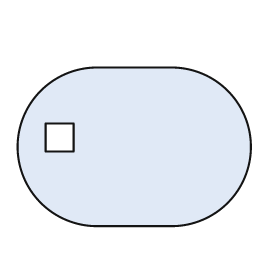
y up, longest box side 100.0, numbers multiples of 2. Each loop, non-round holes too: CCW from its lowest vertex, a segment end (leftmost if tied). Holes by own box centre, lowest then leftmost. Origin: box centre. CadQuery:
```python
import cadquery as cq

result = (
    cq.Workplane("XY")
    .moveTo(-16.0, -34.0)
    .lineTo(16.0, -34.0)
    .threePointArc((50.0, 0.0), (16.0, 34.0))
    .lineTo(-16.0, 34.0)
    .threePointArc((-50.0, 0.0), (-16.0, -34.0))
    .close()
    .moveTo(-38.0, -2.0)
    .lineTo(-26.0, -2.0)
    .lineTo(-26.0, 10.0)
    .lineTo(-38.0, 10.0)
    .close()
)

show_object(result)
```